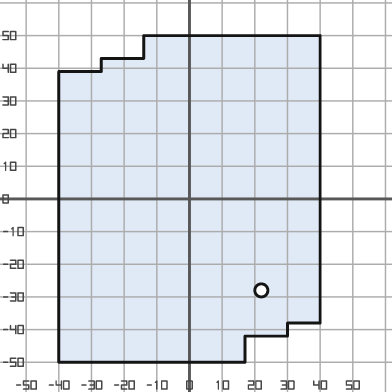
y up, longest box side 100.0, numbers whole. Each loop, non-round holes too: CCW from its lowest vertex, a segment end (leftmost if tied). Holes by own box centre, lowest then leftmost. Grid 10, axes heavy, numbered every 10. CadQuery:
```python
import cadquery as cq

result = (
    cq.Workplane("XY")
    .moveTo(-40.0, -50.0)
    .lineTo(17.0, -50.0)
    .lineTo(17.0, -42.0)
    .lineTo(30.0, -42.0)
    .lineTo(30.0, -38.0)
    .lineTo(40.0, -38.0)
    .lineTo(40.0, 50.0)
    .lineTo(-14.0, 50.0)
    .lineTo(-14.0, 43.0)
    .lineTo(-27.0, 43.0)
    .lineTo(-27.0, 39.0)
    .lineTo(-40.0, 39.0)
    .close()
    .moveTo(22.0, -28.0)
    .circle(2.0)
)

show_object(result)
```